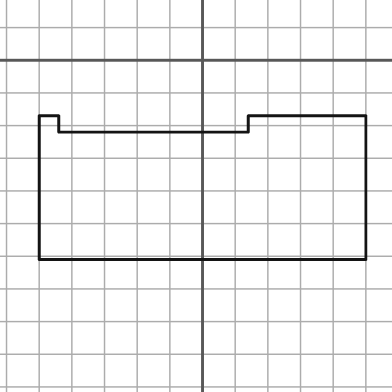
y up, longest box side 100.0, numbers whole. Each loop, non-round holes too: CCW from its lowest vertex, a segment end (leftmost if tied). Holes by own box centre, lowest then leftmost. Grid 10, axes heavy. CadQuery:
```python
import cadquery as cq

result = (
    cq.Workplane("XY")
    .moveTo(-50.0, -61.0)
    .lineTo(50.0, -61.0)
    .lineTo(50.0, -17.0)
    .lineTo(14.0, -17.0)
    .lineTo(14.0, -22.0)
    .lineTo(-44.0, -22.0)
    .lineTo(-44.0, -17.0)
    .lineTo(-50.0, -17.0)
    .close()
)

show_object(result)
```